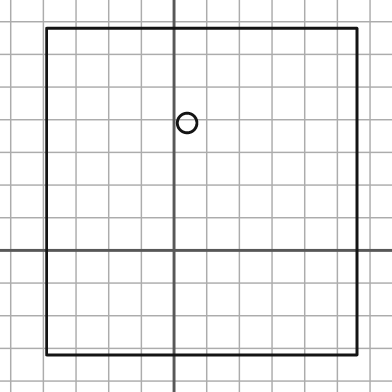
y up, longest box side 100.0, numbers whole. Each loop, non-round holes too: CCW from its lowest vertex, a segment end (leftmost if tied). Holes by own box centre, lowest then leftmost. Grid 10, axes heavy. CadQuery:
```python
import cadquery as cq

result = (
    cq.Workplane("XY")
    .moveTo(-39.0, -32.0)
    .lineTo(56.0, -32.0)
    .lineTo(56.0, 68.0)
    .lineTo(-39.0, 68.0)
    .close()
    .moveTo(4.0, 39.0)
    .circle(3.0)
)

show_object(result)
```